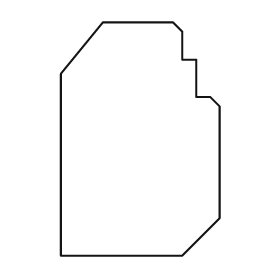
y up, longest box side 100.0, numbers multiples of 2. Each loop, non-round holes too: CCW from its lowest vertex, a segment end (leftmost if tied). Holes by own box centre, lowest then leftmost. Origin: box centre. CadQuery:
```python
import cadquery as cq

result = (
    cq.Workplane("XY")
    .moveTo(-34.0, -50.0)
    .lineTo(18.0, -50.0)
    .lineTo(34.0, -34.0)
    .lineTo(34.0, 14.0)
    .lineTo(30.0, 18.0)
    .lineTo(24.0, 18.0)
    .lineTo(24.0, 34.0)
    .lineTo(18.0, 34.0)
    .lineTo(18.0, 46.0)
    .lineTo(14.0, 50.0)
    .lineTo(-16.0, 50.0)
    .lineTo(-34.0, 28.0)
    .close()
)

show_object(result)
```